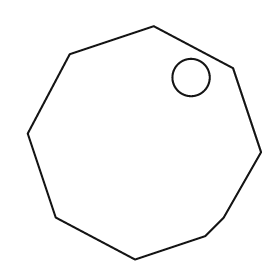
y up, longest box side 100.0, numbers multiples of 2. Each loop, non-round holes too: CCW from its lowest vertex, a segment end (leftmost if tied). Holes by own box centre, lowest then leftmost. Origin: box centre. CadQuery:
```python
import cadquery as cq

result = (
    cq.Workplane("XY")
    .moveTo(-4.0, -50.0)
    .lineTo(26.0, -40.0)
    .lineTo(34.0, -32.0)
    .lineTo(50.0, -4.0)
    .lineTo(38.0, 32.0)
    .lineTo(4.0, 50.0)
    .lineTo(-32.0, 38.0)
    .lineTo(-50.0, 4.0)
    .lineTo(-38.0, -32.0)
    .close()
    .moveTo(20.0, 28.0)
    .circle(8.0)
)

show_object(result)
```